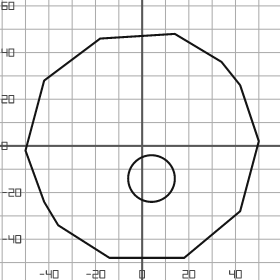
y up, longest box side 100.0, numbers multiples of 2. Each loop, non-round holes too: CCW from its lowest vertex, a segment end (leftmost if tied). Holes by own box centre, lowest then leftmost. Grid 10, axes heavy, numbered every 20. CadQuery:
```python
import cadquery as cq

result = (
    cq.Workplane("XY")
    .moveTo(-14.0, -48.0)
    .lineTo(18.0, -48.0)
    .lineTo(42.0, -28.0)
    .lineTo(50.0, 2.0)
    .lineTo(42.0, 26.0)
    .lineTo(34.0, 36.0)
    .lineTo(14.0, 48.0)
    .lineTo(-18.0, 46.0)
    .lineTo(-42.0, 28.0)
    .lineTo(-50.0, -2.0)
    .lineTo(-42.0, -24.0)
    .lineTo(-36.0, -34.0)
    .close()
    .moveTo(4.0, -14.0)
    .circle(10.0)
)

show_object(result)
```